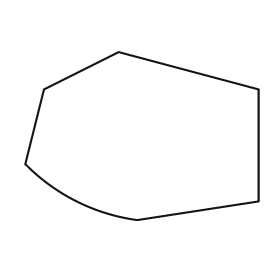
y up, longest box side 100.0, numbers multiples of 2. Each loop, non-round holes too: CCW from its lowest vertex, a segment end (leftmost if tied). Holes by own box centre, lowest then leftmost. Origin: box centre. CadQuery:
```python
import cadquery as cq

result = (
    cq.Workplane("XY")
    .moveTo(-2.0, -36.0)
    .lineTo(50.0, -28.0)
    .lineTo(50.0, 20.0)
    .lineTo(-10.0, 36.0)
    .lineTo(-42.0, 20.0)
    .lineTo(-50.0, -12.0)
    .threePointArc((-28.0, -28.0), (-2.0, -36.0))
    .close()
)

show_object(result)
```